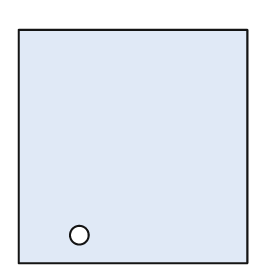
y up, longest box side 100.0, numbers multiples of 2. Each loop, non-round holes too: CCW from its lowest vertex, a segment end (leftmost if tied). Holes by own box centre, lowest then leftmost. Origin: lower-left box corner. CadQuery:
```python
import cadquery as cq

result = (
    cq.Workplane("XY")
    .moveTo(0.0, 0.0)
    .lineTo(98.0, 0.0)
    .lineTo(98.0, 100.0)
    .lineTo(0.0, 100.0)
    .close()
    .moveTo(26.0, 12.0)
    .circle(4.0)
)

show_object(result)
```